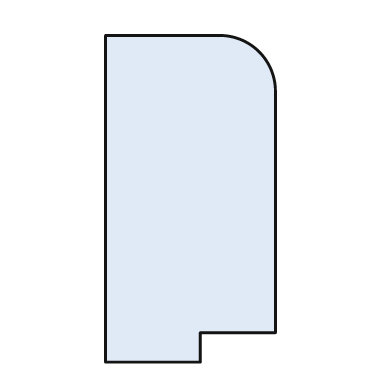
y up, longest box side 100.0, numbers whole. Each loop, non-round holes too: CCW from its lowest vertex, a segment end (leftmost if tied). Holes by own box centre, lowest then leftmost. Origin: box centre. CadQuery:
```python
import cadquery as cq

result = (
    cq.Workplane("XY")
    .moveTo(-26.0, -50.0)
    .lineTo(3.0, -50.0)
    .lineTo(3.0, -41.0)
    .lineTo(26.0, -41.0)
    .lineTo(26.0, 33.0)
    .threePointArc((21.0, 45.0), (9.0, 50.0))
    .lineTo(-26.0, 50.0)
    .close()
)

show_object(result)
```